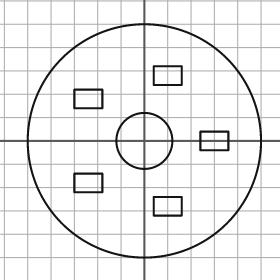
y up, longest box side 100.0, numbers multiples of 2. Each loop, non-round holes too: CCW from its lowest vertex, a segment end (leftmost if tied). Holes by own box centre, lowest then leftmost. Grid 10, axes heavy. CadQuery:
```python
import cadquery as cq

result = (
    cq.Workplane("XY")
    .moveTo(0.0, 0.0)
    .circle(50.0)
    .moveTo(4.0, -32.0)
    .lineTo(16.0, -32.0)
    .lineTo(16.0, -24.0)
    .lineTo(4.0, -24.0)
    .close()
    .moveTo(-30.0, -22.0)
    .lineTo(-18.0, -22.0)
    .lineTo(-18.0, -14.0)
    .lineTo(-30.0, -14.0)
    .close()
    .moveTo(0.0, 0.0)
    .circle(12.0)
    .moveTo(24.0, -4.0)
    .lineTo(36.0, -4.0)
    .lineTo(36.0, 4.0)
    .lineTo(24.0, 4.0)
    .close()
    .moveTo(-30.0, 14.0)
    .lineTo(-18.0, 14.0)
    .lineTo(-18.0, 22.0)
    .lineTo(-30.0, 22.0)
    .close()
    .moveTo(4.0, 24.0)
    .lineTo(16.0, 24.0)
    .lineTo(16.0, 32.0)
    .lineTo(4.0, 32.0)
    .close()
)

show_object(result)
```